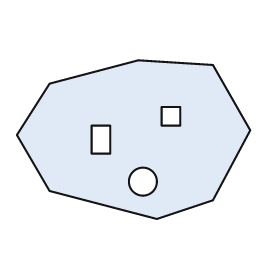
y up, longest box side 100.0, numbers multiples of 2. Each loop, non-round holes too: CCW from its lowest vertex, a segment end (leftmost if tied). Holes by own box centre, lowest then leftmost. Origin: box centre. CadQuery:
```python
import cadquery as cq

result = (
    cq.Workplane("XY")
    .moveTo(10.0, -34.0)
    .lineTo(34.0, -26.0)
    .lineTo(50.0, 4.0)
    .lineTo(34.0, 32.0)
    .lineTo(2.0, 34.0)
    .lineTo(-36.0, 24.0)
    .lineTo(-50.0, 2.0)
    .lineTo(-36.0, -22.0)
    .close()
    .moveTo(4.0, -18.0)
    .circle(6.0)
    .moveTo(-18.0, -6.0)
    .lineTo(-10.0, -6.0)
    .lineTo(-10.0, 6.0)
    .lineTo(-18.0, 6.0)
    .close()
    .moveTo(12.0, 6.0)
    .lineTo(20.0, 6.0)
    .lineTo(20.0, 14.0)
    .lineTo(12.0, 14.0)
    .close()
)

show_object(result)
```